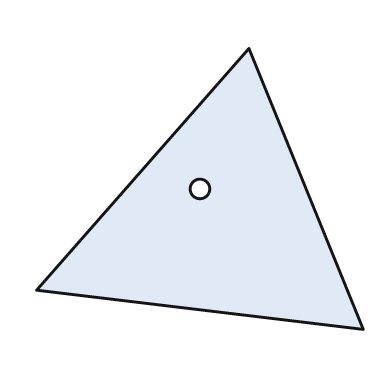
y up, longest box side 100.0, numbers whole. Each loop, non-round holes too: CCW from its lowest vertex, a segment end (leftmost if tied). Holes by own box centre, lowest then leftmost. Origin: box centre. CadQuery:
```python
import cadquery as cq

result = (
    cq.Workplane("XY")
    .moveTo(50.0, -43.0)
    .lineTo(15.0, 43.0)
    .lineTo(-50.0, -31.0)
    .close()
    .moveTo(0.0, 0.0)
    .circle(3.0)
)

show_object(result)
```